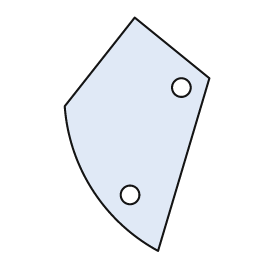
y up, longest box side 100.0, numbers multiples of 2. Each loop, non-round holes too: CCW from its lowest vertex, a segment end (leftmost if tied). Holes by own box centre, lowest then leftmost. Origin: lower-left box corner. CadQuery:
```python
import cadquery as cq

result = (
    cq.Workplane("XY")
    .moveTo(40.0, 0.0)
    .lineTo(62.0, 74.0)
    .lineTo(30.0, 100.0)
    .lineTo(0.0, 62.0)
    .threePointArc((12.0, 26.0), (40.0, 0.0))
    .close()
    .moveTo(28.0, 24.0)
    .circle(4.0)
    .moveTo(50.0, 70.0)
    .circle(4.0)
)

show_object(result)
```